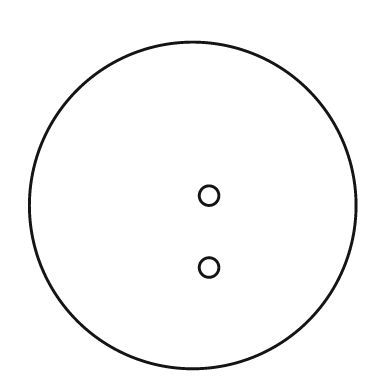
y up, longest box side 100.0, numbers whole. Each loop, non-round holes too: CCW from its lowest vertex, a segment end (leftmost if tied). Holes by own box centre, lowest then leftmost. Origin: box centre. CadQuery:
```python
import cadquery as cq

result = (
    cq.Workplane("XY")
    .moveTo(0.0, 0.0)
    .circle(50.0)
    .moveTo(5.0, -19.0)
    .circle(3.0)
    .moveTo(5.0, 3.0)
    .circle(3.0)
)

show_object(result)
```